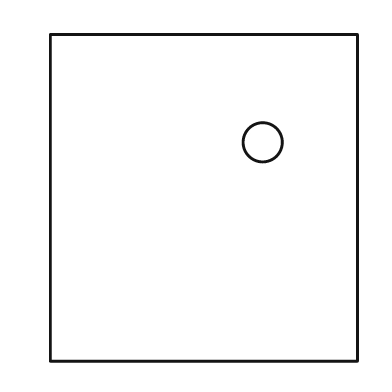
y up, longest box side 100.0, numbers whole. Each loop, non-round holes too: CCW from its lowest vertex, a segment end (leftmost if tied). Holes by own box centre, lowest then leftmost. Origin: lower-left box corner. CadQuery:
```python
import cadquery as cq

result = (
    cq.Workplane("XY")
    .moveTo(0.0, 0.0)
    .lineTo(94.0, 0.0)
    .lineTo(94.0, 100.0)
    .lineTo(0.0, 100.0)
    .close()
    .moveTo(65.0, 67.0)
    .circle(6.0)
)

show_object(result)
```